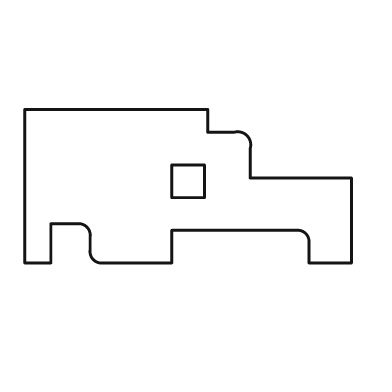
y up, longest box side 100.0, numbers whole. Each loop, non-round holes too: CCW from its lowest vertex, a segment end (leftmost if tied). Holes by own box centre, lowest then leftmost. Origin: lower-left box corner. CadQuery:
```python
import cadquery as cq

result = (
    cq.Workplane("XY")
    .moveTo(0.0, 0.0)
    .lineTo(8.0, 0.0)
    .lineTo(8.0, 12.0)
    .lineTo(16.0, 12.0)
    .threePointArc((19.0, 11.0), (20.0, 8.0))
    .lineTo(20.0, 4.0)
    .threePointArc((21.0, 1.0), (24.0, 0.0))
    .lineTo(45.0, 0.0)
    .lineTo(45.0, 10.0)
    .lineTo(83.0, 10.0)
    .threePointArc((86.0, 9.0), (87.0, 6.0))
    .lineTo(87.0, 0.0)
    .lineTo(100.0, 0.0)
    .lineTo(100.0, 26.0)
    .lineTo(69.0, 26.0)
    .lineTo(69.0, 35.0)
    .threePointArc((68.0, 39.0), (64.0, 40.0))
    .lineTo(56.0, 40.0)
    .lineTo(56.0, 47.0)
    .lineTo(0.0, 47.0)
    .close()
    .moveTo(45.0, 20.0)
    .lineTo(55.0, 20.0)
    .lineTo(55.0, 30.0)
    .lineTo(45.0, 30.0)
    .close()
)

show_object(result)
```